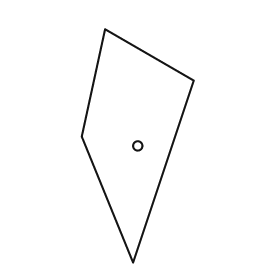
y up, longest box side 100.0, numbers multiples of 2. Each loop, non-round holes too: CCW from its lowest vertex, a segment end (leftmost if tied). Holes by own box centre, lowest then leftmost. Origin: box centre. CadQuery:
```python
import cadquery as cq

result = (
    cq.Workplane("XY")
    .moveTo(-2.0, -50.0)
    .lineTo(24.0, 28.0)
    .lineTo(-14.0, 50.0)
    .lineTo(-24.0, 4.0)
    .close()
    .moveTo(0.0, 0.0)
    .circle(2.0)
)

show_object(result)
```